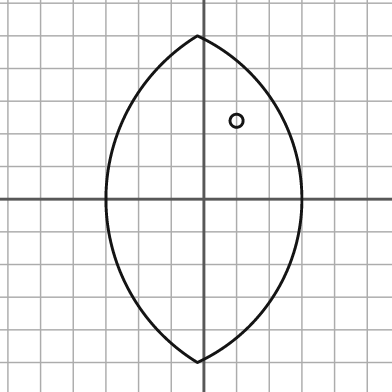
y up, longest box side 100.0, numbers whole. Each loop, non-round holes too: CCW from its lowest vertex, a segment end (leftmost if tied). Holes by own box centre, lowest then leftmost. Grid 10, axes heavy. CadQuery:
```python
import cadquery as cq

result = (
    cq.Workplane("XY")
    .moveTo(-2.0, -50.0)
    .threePointArc((30.0, 0.0), (-2.0, 50.0))
    .threePointArc((-30.0, 0.0), (-2.0, -50.0))
    .close()
    .moveTo(10.0, 24.0)
    .circle(2.0)
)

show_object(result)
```